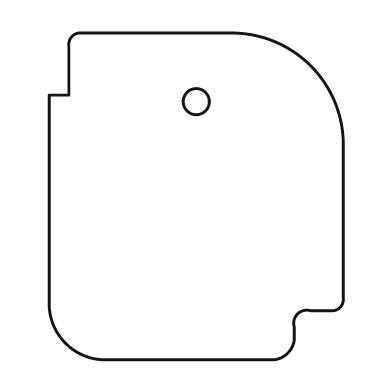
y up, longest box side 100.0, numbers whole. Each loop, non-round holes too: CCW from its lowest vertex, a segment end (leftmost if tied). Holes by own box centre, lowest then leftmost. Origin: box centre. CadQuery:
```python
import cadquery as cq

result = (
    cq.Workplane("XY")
    .moveTo(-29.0, -50.0)
    .lineTo(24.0, -50.0)
    .threePointArc((28.0, -48.0), (30.0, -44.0))
    .lineTo(30.0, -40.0)
    .threePointArc((31.0, -36.0), (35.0, -35.0))
    .lineTo(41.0, -35.0)
    .threePointArc((44.0, -34.0), (45.0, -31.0))
    .lineTo(45.0, 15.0)
    .threePointArc((35.0, 40.0), (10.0, 50.0))
    .lineTo(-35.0, 50.0)
    .threePointArc((-38.0, 49.0), (-39.0, 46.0))
    .lineTo(-39.0, 31.0)
    .lineTo(-45.0, 31.0)
    .lineTo(-45.0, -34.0)
    .threePointArc((-40.0, -45.0), (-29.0, -50.0))
    .close()
    .moveTo(0.0, 29.0)
    .circle(4.0)
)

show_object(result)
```